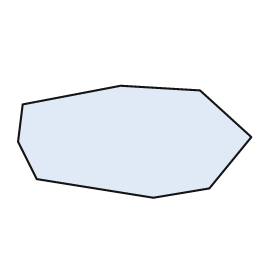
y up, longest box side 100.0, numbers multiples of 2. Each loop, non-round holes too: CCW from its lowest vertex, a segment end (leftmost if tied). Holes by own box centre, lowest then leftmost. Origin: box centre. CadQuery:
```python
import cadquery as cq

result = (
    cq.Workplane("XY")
    .moveTo(8.0, -24.0)
    .lineTo(32.0, -20.0)
    .lineTo(50.0, 2.0)
    .lineTo(28.0, 22.0)
    .lineTo(-6.0, 24.0)
    .lineTo(-48.0, 16.0)
    .lineTo(-50.0, 0.0)
    .lineTo(-42.0, -16.0)
    .close()
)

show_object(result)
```